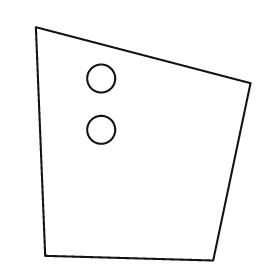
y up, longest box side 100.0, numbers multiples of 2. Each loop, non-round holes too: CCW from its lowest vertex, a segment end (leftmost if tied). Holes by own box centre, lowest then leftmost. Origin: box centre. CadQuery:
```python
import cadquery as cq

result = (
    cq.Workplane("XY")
    .moveTo(30.0, -50.0)
    .lineTo(46.0, 26.0)
    .lineTo(-46.0, 50.0)
    .lineTo(-42.0, -48.0)
    .close()
    .moveTo(-18.0, 6.0)
    .circle(6.0)
    .moveTo(-18.0, 28.0)
    .circle(6.0)
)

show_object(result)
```